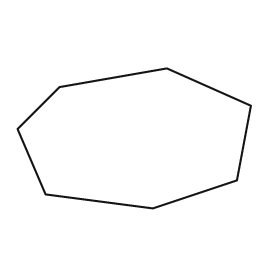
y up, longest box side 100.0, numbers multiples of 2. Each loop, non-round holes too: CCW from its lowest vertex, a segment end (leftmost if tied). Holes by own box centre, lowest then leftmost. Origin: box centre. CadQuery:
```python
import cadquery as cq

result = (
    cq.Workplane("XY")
    .moveTo(8.0, -30.0)
    .lineTo(44.0, -18.0)
    .lineTo(50.0, 14.0)
    .lineTo(14.0, 30.0)
    .lineTo(-32.0, 22.0)
    .lineTo(-50.0, 4.0)
    .lineTo(-38.0, -24.0)
    .close()
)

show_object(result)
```